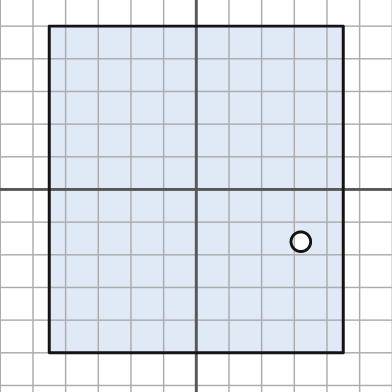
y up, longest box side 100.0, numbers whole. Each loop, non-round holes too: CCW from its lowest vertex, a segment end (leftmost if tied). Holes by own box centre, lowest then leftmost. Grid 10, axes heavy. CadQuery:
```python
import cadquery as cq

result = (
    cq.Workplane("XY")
    .moveTo(-45.0, -50.0)
    .lineTo(45.0, -50.0)
    .lineTo(45.0, 50.0)
    .lineTo(-45.0, 50.0)
    .close()
    .moveTo(32.0, -16.0)
    .circle(3.0)
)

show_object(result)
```